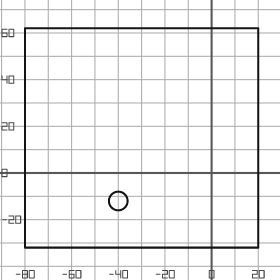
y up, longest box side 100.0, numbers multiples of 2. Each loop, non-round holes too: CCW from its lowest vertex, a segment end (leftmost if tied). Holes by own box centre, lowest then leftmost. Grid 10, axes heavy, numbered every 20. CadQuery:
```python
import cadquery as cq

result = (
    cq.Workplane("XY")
    .moveTo(-80.0, -32.0)
    .lineTo(20.0, -32.0)
    .lineTo(20.0, 62.0)
    .lineTo(-80.0, 62.0)
    .close()
    .moveTo(-40.0, -12.0)
    .circle(4.0)
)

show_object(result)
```